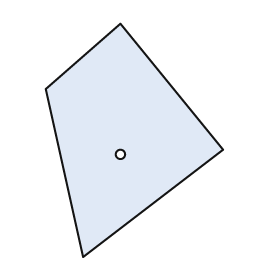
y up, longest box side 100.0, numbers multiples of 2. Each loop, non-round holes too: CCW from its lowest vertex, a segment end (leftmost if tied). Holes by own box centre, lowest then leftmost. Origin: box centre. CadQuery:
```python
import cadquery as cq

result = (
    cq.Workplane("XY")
    .moveTo(-22.0, -50.0)
    .lineTo(38.0, -4.0)
    .lineTo(-6.0, 50.0)
    .lineTo(-38.0, 22.0)
    .close()
    .moveTo(-6.0, -6.0)
    .circle(2.0)
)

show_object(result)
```